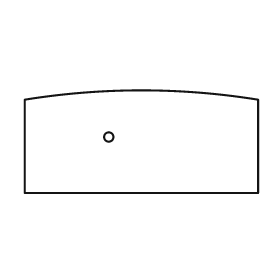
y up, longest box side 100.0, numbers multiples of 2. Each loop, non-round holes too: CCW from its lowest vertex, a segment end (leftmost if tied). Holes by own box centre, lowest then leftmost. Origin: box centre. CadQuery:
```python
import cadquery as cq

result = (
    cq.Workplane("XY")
    .moveTo(-50.0, -22.0)
    .lineTo(50.0, -22.0)
    .lineTo(50.0, 18.0)
    .threePointArc((0.0, 22.0), (-50.0, 18.0))
    .close()
    .moveTo(-14.0, 2.0)
    .circle(2.0)
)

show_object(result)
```